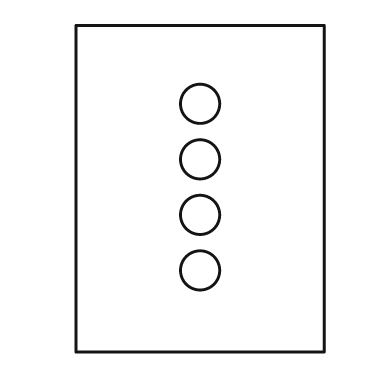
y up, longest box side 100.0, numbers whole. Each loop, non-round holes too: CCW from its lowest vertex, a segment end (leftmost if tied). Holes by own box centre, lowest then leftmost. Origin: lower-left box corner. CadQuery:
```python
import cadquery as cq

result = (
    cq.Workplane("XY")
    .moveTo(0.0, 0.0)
    .lineTo(76.0, 0.0)
    .lineTo(76.0, 100.0)
    .lineTo(0.0, 100.0)
    .close()
    .moveTo(38.0, 25.0)
    .circle(6.0)
    .moveTo(38.0, 42.0)
    .circle(6.0)
    .moveTo(38.0, 59.0)
    .circle(6.0)
    .moveTo(38.0, 76.0)
    .circle(6.0)
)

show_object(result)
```